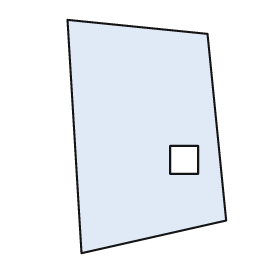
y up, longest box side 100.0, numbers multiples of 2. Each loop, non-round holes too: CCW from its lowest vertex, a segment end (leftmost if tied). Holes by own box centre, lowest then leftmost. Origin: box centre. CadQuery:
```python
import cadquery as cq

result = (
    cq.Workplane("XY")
    .moveTo(-28.0, -50.0)
    .lineTo(34.0, -36.0)
    .lineTo(26.0, 44.0)
    .lineTo(-34.0, 50.0)
    .close()
    .moveTo(10.0, -16.0)
    .lineTo(22.0, -16.0)
    .lineTo(22.0, -4.0)
    .lineTo(10.0, -4.0)
    .close()
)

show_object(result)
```